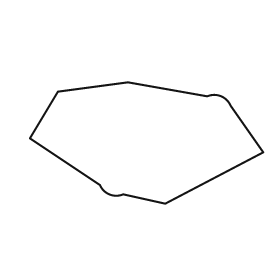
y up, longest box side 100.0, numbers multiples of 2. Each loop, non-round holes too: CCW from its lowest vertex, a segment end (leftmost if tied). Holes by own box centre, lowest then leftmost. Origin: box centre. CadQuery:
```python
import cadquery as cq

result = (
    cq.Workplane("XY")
    .moveTo(8.0, -26.0)
    .lineTo(50.0, -4.0)
    .lineTo(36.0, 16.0)
    .threePointArc((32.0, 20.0), (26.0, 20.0))
    .lineTo(-8.0, 26.0)
    .lineTo(-38.0, 22.0)
    .lineTo(-50.0, 2.0)
    .lineTo(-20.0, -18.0)
    .threePointArc((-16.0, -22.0), (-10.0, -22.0))
    .close()
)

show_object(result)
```